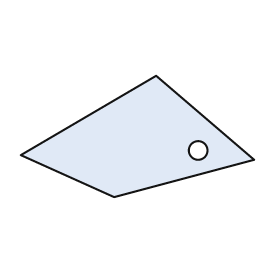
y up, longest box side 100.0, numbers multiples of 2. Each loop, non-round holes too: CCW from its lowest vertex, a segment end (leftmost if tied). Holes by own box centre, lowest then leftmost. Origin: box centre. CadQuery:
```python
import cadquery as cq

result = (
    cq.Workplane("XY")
    .moveTo(-10.0, -26.0)
    .lineTo(50.0, -10.0)
    .lineTo(8.0, 26.0)
    .lineTo(-50.0, -8.0)
    .close()
    .moveTo(26.0, -6.0)
    .circle(4.0)
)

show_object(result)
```